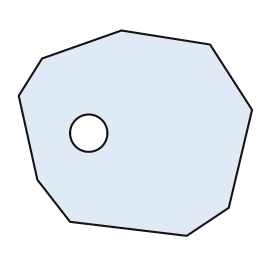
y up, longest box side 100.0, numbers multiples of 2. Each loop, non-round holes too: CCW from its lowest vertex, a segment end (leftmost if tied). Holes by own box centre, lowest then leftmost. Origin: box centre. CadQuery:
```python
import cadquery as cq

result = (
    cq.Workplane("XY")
    .moveTo(22.0, -44.0)
    .lineTo(40.0, -32.0)
    .lineTo(50.0, 10.0)
    .lineTo(32.0, 38.0)
    .lineTo(-6.0, 44.0)
    .lineTo(-40.0, 32.0)
    .lineTo(-50.0, 16.0)
    .lineTo(-42.0, -20.0)
    .lineTo(-28.0, -38.0)
    .close()
    .moveTo(-20.0, 0.0)
    .circle(8.0)
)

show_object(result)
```